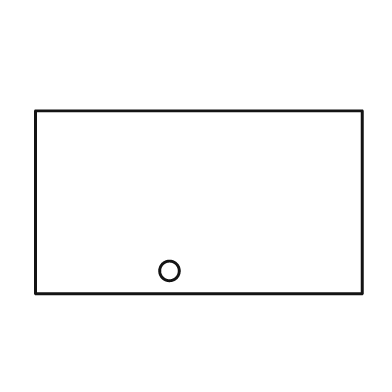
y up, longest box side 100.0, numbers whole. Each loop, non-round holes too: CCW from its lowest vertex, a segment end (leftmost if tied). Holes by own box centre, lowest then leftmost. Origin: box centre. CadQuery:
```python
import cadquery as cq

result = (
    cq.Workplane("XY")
    .moveTo(-50.0, -28.0)
    .lineTo(50.0, -28.0)
    .lineTo(50.0, 28.0)
    .lineTo(-50.0, 28.0)
    .close()
    .moveTo(-9.0, -21.0)
    .circle(3.0)
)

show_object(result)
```